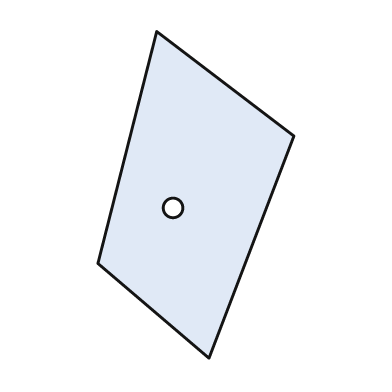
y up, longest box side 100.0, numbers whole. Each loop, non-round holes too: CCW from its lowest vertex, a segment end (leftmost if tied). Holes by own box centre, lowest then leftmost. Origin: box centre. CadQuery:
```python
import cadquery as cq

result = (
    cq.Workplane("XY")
    .moveTo(4.0, -50.0)
    .lineTo(30.0, 18.0)
    .lineTo(-12.0, 50.0)
    .lineTo(-30.0, -21.0)
    .close()
    .moveTo(-7.0, -4.0)
    .circle(3.0)
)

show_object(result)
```